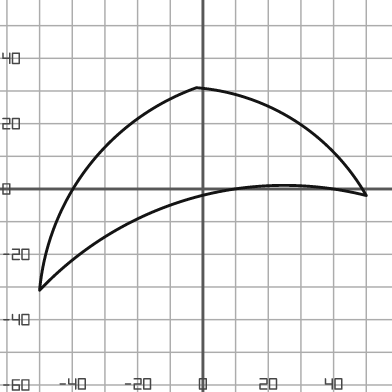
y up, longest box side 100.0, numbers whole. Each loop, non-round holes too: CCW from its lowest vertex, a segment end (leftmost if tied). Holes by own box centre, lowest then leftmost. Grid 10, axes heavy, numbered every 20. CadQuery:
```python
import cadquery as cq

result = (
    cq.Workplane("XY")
    .moveTo(-50.0, -31.0)
    .threePointArc((-4.0, -3.0), (50.0, -2.0))
    .threePointArc((28.0, 21.0), (-2.0, 31.0))
    .threePointArc((-35.0, 7.0), (-50.0, -31.0))
    .close()
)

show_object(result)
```